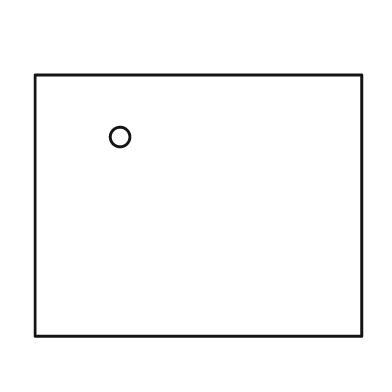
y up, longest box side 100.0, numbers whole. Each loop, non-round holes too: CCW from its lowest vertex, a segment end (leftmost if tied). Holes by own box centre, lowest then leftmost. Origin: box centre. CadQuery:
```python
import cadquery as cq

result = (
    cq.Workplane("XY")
    .moveTo(-50.0, -40.0)
    .lineTo(50.0, -40.0)
    .lineTo(50.0, 40.0)
    .lineTo(-50.0, 40.0)
    .close()
    .moveTo(-24.0, 21.0)
    .circle(3.0)
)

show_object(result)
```